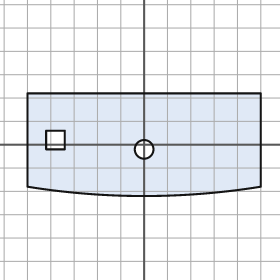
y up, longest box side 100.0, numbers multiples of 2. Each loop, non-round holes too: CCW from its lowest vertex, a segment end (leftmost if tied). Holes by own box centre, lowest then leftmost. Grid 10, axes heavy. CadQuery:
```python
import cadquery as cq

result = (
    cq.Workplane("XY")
    .moveTo(-50.0, -18.0)
    .threePointArc((0.0, -22.0), (50.0, -18.0))
    .lineTo(50.0, 22.0)
    .lineTo(-50.0, 22.0)
    .close()
    .moveTo(0.0, -2.0)
    .circle(4.0)
    .moveTo(-42.0, -2.0)
    .lineTo(-34.0, -2.0)
    .lineTo(-34.0, 6.0)
    .lineTo(-42.0, 6.0)
    .close()
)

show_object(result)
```